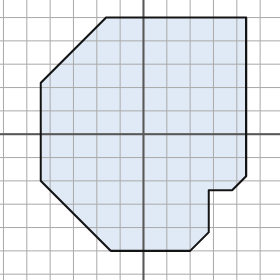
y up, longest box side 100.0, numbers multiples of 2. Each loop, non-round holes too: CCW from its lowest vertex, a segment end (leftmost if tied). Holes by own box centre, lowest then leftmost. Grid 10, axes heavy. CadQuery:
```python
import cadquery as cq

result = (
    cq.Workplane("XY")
    .moveTo(-14.0, -50.0)
    .lineTo(20.0, -50.0)
    .lineTo(28.0, -42.0)
    .lineTo(28.0, -24.0)
    .lineTo(38.0, -24.0)
    .lineTo(44.0, -18.0)
    .lineTo(44.0, 50.0)
    .lineTo(-16.0, 50.0)
    .lineTo(-44.0, 22.0)
    .lineTo(-44.0, -20.0)
    .close()
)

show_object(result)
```